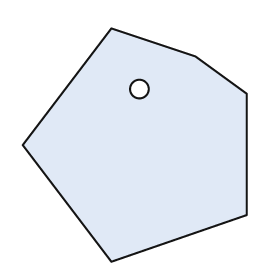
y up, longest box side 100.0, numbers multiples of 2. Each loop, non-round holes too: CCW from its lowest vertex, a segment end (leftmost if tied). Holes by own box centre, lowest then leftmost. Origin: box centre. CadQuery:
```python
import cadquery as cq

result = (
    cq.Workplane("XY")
    .moveTo(-10.0, -50.0)
    .lineTo(48.0, -30.0)
    .lineTo(48.0, 22.0)
    .lineTo(26.0, 38.0)
    .lineTo(-10.0, 50.0)
    .lineTo(-48.0, 0.0)
    .close()
    .moveTo(2.0, 24.0)
    .circle(4.0)
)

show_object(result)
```